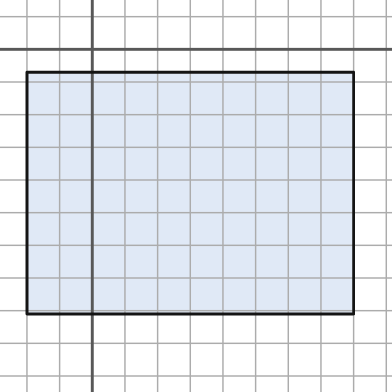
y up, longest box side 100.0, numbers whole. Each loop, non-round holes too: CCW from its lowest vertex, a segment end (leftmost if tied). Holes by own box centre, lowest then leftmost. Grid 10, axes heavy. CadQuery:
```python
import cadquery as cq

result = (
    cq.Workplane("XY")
    .moveTo(-20.0, -81.0)
    .lineTo(80.0, -81.0)
    .lineTo(80.0, -7.0)
    .lineTo(-20.0, -7.0)
    .close()
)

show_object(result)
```